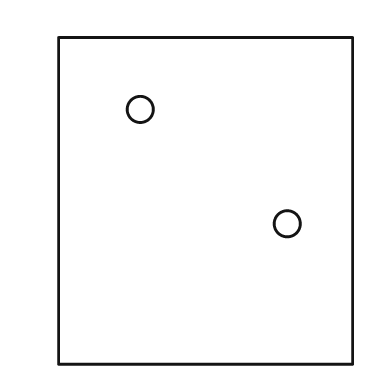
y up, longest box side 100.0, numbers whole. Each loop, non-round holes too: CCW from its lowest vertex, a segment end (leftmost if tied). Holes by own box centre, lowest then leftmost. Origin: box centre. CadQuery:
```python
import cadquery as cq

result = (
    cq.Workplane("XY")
    .moveTo(-45.0, -50.0)
    .lineTo(45.0, -50.0)
    .lineTo(45.0, 50.0)
    .lineTo(-45.0, 50.0)
    .close()
    .moveTo(25.0, -7.0)
    .circle(4.0)
    .moveTo(-20.0, 28.0)
    .circle(4.0)
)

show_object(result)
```